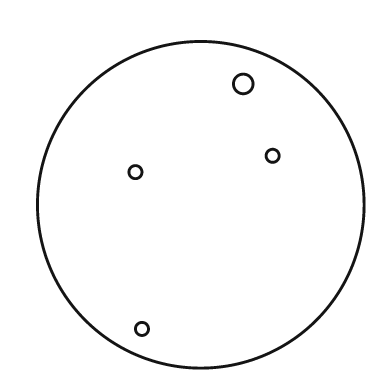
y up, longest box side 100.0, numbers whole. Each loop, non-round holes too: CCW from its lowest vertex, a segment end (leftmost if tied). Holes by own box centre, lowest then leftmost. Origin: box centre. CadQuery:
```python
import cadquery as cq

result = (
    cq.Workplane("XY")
    .moveTo(0.0, 0.0)
    .circle(50.0)
    .moveTo(-18.0, -38.0)
    .circle(2.0)
    .moveTo(-20.0, 10.0)
    .circle(2.0)
    .moveTo(22.0, 15.0)
    .circle(2.0)
    .moveTo(13.0, 37.0)
    .circle(3.0)
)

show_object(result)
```